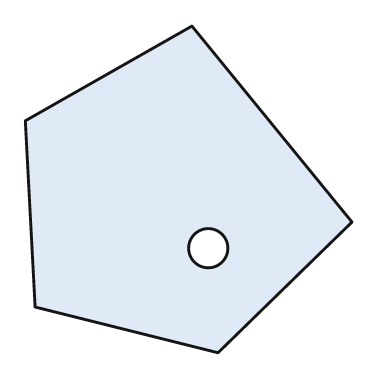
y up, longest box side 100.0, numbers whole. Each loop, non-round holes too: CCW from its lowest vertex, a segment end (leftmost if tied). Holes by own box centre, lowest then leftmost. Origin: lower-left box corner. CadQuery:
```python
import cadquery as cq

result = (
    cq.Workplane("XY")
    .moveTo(59.0, 0.0)
    .lineTo(100.0, 40.0)
    .lineTo(51.0, 100.0)
    .lineTo(0.0, 71.0)
    .lineTo(3.0, 14.0)
    .close()
    .moveTo(56.0, 32.0)
    .circle(6.0)
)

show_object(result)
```